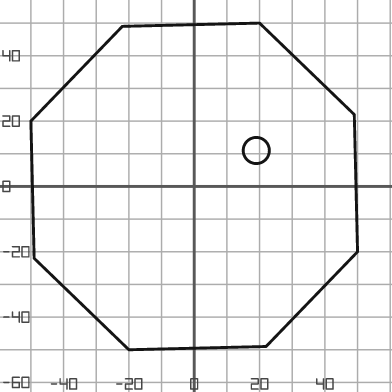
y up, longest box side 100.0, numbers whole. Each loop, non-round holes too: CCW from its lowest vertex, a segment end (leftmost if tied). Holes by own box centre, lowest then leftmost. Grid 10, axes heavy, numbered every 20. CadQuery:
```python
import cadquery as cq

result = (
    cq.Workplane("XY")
    .moveTo(-20.0, -50.0)
    .lineTo(22.0, -49.0)
    .lineTo(50.0, -20.0)
    .lineTo(49.0, 22.0)
    .lineTo(20.0, 50.0)
    .lineTo(-22.0, 49.0)
    .lineTo(-50.0, 20.0)
    .lineTo(-49.0, -22.0)
    .close()
    .moveTo(19.0, 11.0)
    .circle(4.0)
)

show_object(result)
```